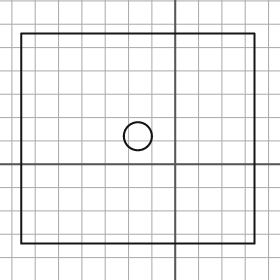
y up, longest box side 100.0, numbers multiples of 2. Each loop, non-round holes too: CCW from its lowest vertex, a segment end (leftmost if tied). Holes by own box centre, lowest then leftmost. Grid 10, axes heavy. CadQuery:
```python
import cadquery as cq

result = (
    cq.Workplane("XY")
    .moveTo(-66.0, -34.0)
    .lineTo(34.0, -34.0)
    .lineTo(34.0, 56.0)
    .lineTo(-66.0, 56.0)
    .close()
    .moveTo(-16.0, 12.0)
    .circle(6.0)
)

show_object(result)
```